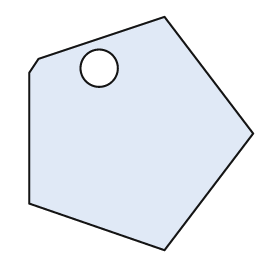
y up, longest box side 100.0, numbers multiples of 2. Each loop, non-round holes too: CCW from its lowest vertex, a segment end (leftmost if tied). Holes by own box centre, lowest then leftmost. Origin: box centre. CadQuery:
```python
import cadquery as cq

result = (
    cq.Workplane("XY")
    .moveTo(10.0, -50.0)
    .lineTo(48.0, 0.0)
    .lineTo(10.0, 50.0)
    .lineTo(-44.0, 32.0)
    .lineTo(-48.0, 26.0)
    .lineTo(-48.0, -30.0)
    .close()
    .moveTo(-18.0, 28.0)
    .circle(8.0)
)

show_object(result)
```